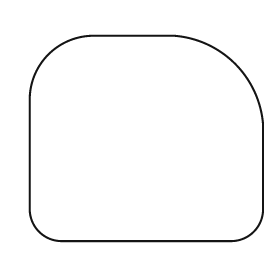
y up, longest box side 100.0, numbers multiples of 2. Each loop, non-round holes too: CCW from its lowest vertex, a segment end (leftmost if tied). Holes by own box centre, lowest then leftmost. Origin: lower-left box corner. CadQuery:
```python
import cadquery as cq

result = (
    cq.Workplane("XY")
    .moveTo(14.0, 0.0)
    .lineTo(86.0, 0.0)
    .threePointArc((96.0, 4.0), (100.0, 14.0))
    .lineTo(100.0, 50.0)
    .threePointArc((88.0, 76.0), (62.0, 88.0))
    .lineTo(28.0, 88.0)
    .threePointArc((8.0, 80.0), (0.0, 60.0))
    .lineTo(0.0, 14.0)
    .threePointArc((4.0, 4.0), (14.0, 0.0))
    .close()
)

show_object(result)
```